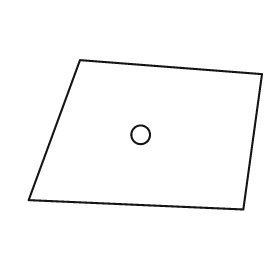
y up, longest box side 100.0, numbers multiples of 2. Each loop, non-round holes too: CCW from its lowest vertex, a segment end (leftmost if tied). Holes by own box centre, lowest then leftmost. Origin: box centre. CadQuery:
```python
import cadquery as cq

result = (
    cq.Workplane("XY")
    .moveTo(42.0, -32.0)
    .lineTo(50.0, 26.0)
    .lineTo(-28.0, 32.0)
    .lineTo(-50.0, -28.0)
    .close()
    .moveTo(-2.0, 0.0)
    .circle(4.0)
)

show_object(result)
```